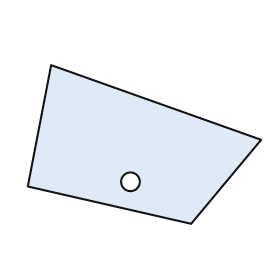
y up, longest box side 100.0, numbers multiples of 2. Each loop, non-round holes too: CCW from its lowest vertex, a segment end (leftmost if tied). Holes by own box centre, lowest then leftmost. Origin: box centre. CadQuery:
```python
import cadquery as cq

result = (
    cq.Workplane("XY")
    .moveTo(20.0, -34.0)
    .lineTo(50.0, 2.0)
    .lineTo(-40.0, 34.0)
    .lineTo(-50.0, -18.0)
    .close()
    .moveTo(-6.0, -16.0)
    .circle(4.0)
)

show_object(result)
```